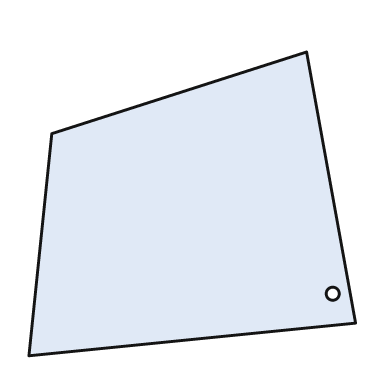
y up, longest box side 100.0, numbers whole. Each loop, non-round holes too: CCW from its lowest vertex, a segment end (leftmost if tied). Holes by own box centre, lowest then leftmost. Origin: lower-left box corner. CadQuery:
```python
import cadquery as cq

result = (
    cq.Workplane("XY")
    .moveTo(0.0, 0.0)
    .lineTo(100.0, 10.0)
    .lineTo(85.0, 93.0)
    .lineTo(7.0, 68.0)
    .close()
    .moveTo(93.0, 19.0)
    .circle(2.0)
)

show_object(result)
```